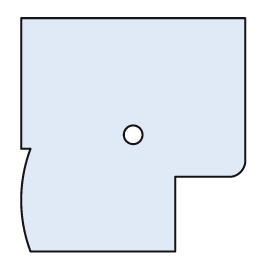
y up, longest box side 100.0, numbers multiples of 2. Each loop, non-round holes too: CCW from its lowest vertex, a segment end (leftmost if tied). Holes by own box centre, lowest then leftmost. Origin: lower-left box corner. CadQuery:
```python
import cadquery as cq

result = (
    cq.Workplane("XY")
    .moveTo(4.0, 0.0)
    .lineTo(66.0, 0.0)
    .lineTo(66.0, 32.0)
    .lineTo(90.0, 32.0)
    .threePointArc((94.0, 34.0), (96.0, 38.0))
    .lineTo(96.0, 100.0)
    .lineTo(0.0, 100.0)
    .lineTo(0.0, 44.0)
    .lineTo(4.0, 44.0)
    .threePointArc((0.0, 22.0), (4.0, 0.0))
    .close()
    .moveTo(48.0, 50.0)
    .circle(4.0)
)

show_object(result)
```